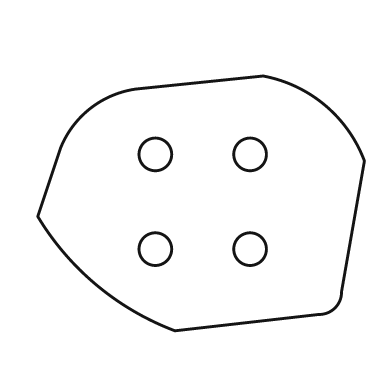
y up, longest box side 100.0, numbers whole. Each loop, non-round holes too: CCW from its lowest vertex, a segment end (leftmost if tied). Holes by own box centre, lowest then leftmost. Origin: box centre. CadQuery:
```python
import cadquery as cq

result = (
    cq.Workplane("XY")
    .moveTo(-8.0, -39.0)
    .lineTo(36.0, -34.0)
    .threePointArc((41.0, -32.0), (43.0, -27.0))
    .lineTo(50.0, 13.0)
    .threePointArc((38.0, 30.0), (19.0, 39.0))
    .lineTo(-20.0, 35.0)
    .threePointArc((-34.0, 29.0), (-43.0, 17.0))
    .lineTo(-50.0, -4.0)
    .threePointArc((-32.0, -25.0), (-8.0, -39.0))
    .close()
    .moveTo(-14.0, -14.0)
    .circle(5.0)
    .moveTo(15.0, -14.0)
    .circle(5.0)
    .moveTo(-14.0, 15.0)
    .circle(5.0)
    .moveTo(15.0, 15.0)
    .circle(5.0)
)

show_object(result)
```